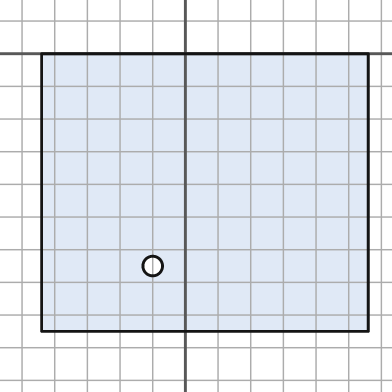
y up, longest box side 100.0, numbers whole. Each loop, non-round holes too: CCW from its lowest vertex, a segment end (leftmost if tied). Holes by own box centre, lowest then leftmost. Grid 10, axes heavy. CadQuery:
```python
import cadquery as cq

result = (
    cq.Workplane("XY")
    .moveTo(-44.0, -85.0)
    .lineTo(56.0, -85.0)
    .lineTo(56.0, 0.0)
    .lineTo(-44.0, 0.0)
    .close()
    .moveTo(-10.0, -65.0)
    .circle(3.0)
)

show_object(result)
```